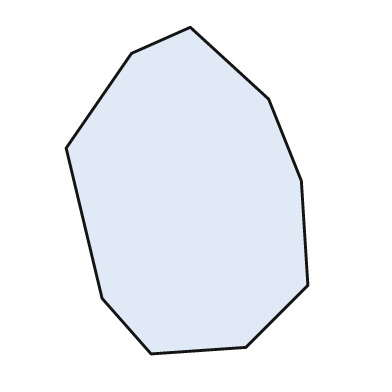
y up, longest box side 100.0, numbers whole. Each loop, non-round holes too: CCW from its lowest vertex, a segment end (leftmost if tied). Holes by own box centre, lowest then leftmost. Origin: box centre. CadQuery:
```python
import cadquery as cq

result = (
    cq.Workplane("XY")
    .moveTo(-11.0, -50.0)
    .lineTo(18.0, -48.0)
    .lineTo(37.0, -29.0)
    .lineTo(35.0, 3.0)
    .lineTo(25.0, 28.0)
    .lineTo(1.0, 50.0)
    .lineTo(-17.0, 42.0)
    .lineTo(-37.0, 13.0)
    .lineTo(-26.0, -33.0)
    .close()
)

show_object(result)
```